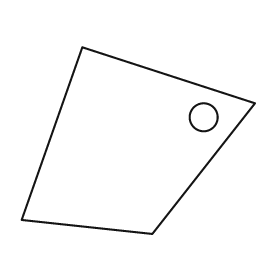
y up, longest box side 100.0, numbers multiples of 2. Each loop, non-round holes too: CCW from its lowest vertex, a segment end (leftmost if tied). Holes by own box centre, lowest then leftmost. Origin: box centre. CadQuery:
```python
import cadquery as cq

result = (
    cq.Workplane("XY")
    .moveTo(6.0, -40.0)
    .lineTo(50.0, 16.0)
    .lineTo(-24.0, 40.0)
    .lineTo(-50.0, -34.0)
    .close()
    .moveTo(28.0, 10.0)
    .circle(6.0)
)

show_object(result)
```